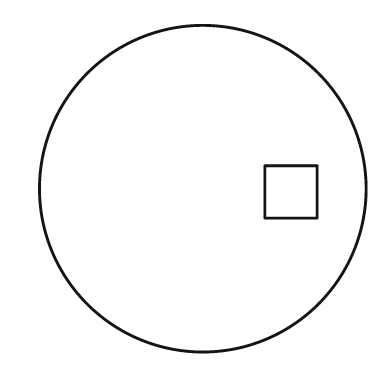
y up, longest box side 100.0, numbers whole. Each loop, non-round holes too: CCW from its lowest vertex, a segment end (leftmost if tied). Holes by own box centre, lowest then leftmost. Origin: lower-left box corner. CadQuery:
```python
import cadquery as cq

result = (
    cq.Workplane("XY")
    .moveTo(50.0, 50.0)
    .circle(50.0)
    .moveTo(69.0, 41.0)
    .lineTo(85.0, 41.0)
    .lineTo(85.0, 57.0)
    .lineTo(69.0, 57.0)
    .close()
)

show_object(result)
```